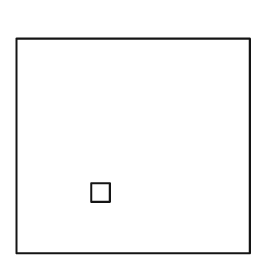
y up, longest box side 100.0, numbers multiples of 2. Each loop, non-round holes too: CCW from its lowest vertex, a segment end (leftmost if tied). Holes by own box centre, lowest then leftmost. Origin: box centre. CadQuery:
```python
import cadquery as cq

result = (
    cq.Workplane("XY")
    .moveTo(-50.0, -46.0)
    .lineTo(50.0, -46.0)
    .lineTo(50.0, 46.0)
    .lineTo(-50.0, 46.0)
    .close()
    .moveTo(-18.0, -24.0)
    .lineTo(-10.0, -24.0)
    .lineTo(-10.0, -16.0)
    .lineTo(-18.0, -16.0)
    .close()
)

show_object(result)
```